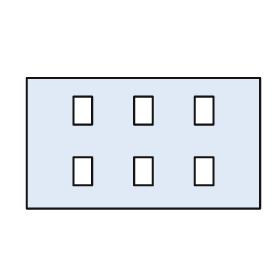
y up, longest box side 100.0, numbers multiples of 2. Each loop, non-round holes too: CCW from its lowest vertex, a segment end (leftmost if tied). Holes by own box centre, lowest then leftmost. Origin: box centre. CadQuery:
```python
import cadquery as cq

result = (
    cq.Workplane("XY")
    .moveTo(-50.0, -28.0)
    .lineTo(50.0, -28.0)
    .lineTo(50.0, 28.0)
    .lineTo(-50.0, 28.0)
    .close()
    .moveTo(-30.0, -18.0)
    .lineTo(-22.0, -18.0)
    .lineTo(-22.0, -6.0)
    .lineTo(-30.0, -6.0)
    .close()
    .moveTo(-4.0, -18.0)
    .lineTo(4.0, -18.0)
    .lineTo(4.0, -6.0)
    .lineTo(-4.0, -6.0)
    .close()
    .moveTo(22.0, -18.0)
    .lineTo(30.0, -18.0)
    .lineTo(30.0, -6.0)
    .lineTo(22.0, -6.0)
    .close()
    .moveTo(-30.0, 8.0)
    .lineTo(-22.0, 8.0)
    .lineTo(-22.0, 20.0)
    .lineTo(-30.0, 20.0)
    .close()
    .moveTo(-4.0, 8.0)
    .lineTo(4.0, 8.0)
    .lineTo(4.0, 20.0)
    .lineTo(-4.0, 20.0)
    .close()
    .moveTo(22.0, 8.0)
    .lineTo(30.0, 8.0)
    .lineTo(30.0, 20.0)
    .lineTo(22.0, 20.0)
    .close()
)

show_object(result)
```